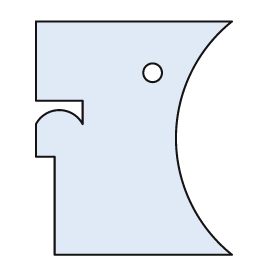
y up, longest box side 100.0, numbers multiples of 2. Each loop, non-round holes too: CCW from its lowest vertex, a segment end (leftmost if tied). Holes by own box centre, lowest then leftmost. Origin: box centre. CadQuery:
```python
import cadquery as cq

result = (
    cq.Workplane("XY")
    .moveTo(-34.0, -50.0)
    .lineTo(42.0, -50.0)
    .threePointArc((18.0, 0.0), (42.0, 50.0))
    .lineTo(-42.0, 50.0)
    .lineTo(-42.0, 16.0)
    .lineTo(-22.0, 16.0)
    .lineTo(-22.0, 6.0)
    .threePointArc((-32.0, 12.0), (-42.0, 6.0))
    .lineTo(-42.0, -8.0)
    .lineTo(-34.0, -8.0)
    .close()
    .moveTo(8.0, 28.0)
    .circle(4.0)
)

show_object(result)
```